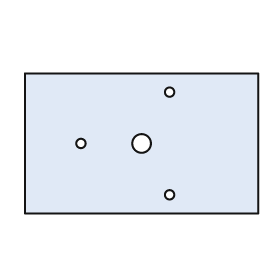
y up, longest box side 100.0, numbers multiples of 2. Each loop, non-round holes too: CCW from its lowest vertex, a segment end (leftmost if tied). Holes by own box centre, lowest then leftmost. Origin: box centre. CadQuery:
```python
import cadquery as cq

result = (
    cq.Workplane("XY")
    .moveTo(-50.0, -30.0)
    .lineTo(50.0, -30.0)
    .lineTo(50.0, 30.0)
    .lineTo(-50.0, 30.0)
    .close()
    .moveTo(12.0, -22.0)
    .circle(2.0)
    .moveTo(-26.0, 0.0)
    .circle(2.0)
    .moveTo(0.0, 0.0)
    .circle(4.0)
    .moveTo(12.0, 22.0)
    .circle(2.0)
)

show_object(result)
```